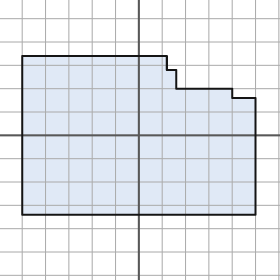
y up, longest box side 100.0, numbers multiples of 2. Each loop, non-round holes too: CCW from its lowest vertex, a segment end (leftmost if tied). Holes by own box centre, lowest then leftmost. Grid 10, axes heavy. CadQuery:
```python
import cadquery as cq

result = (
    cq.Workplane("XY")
    .moveTo(-50.0, -34.0)
    .lineTo(50.0, -34.0)
    .lineTo(50.0, 16.0)
    .lineTo(40.0, 16.0)
    .lineTo(40.0, 20.0)
    .lineTo(16.0, 20.0)
    .lineTo(16.0, 28.0)
    .lineTo(12.0, 28.0)
    .lineTo(12.0, 34.0)
    .lineTo(-50.0, 34.0)
    .close()
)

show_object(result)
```